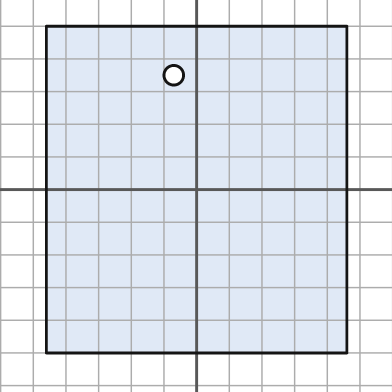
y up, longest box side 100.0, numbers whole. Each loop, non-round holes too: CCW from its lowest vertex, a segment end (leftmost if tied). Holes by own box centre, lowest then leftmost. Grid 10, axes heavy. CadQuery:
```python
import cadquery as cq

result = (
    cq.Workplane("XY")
    .moveTo(-46.0, -50.0)
    .lineTo(46.0, -50.0)
    .lineTo(46.0, 50.0)
    .lineTo(-46.0, 50.0)
    .close()
    .moveTo(-7.0, 35.0)
    .circle(3.0)
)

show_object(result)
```